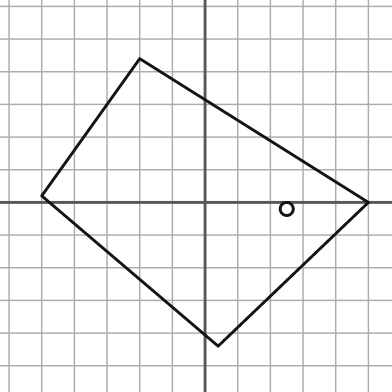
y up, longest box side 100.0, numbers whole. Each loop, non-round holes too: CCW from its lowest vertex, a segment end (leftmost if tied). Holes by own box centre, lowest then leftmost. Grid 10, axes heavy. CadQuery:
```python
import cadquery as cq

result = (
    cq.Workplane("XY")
    .moveTo(4.0, -44.0)
    .lineTo(50.0, 0.0)
    .lineTo(-20.0, 44.0)
    .lineTo(-50.0, 2.0)
    .close()
    .moveTo(25.0, -2.0)
    .circle(2.0)
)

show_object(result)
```